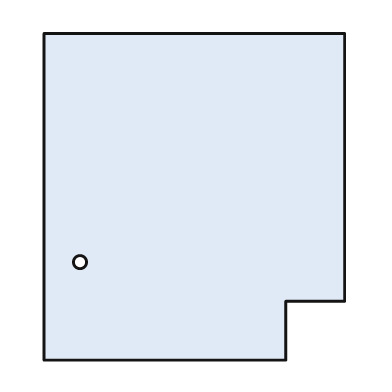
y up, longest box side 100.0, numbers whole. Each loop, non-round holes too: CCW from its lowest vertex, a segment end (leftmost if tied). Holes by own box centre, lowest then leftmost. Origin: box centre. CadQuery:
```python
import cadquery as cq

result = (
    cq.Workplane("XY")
    .moveTo(-46.0, -50.0)
    .lineTo(28.0, -50.0)
    .lineTo(28.0, -32.0)
    .lineTo(46.0, -32.0)
    .lineTo(46.0, 50.0)
    .lineTo(-46.0, 50.0)
    .close()
    .moveTo(-35.0, -20.0)
    .circle(2.0)
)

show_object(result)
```